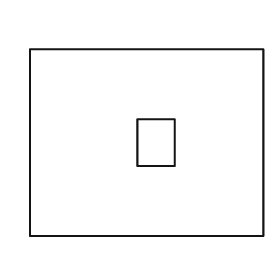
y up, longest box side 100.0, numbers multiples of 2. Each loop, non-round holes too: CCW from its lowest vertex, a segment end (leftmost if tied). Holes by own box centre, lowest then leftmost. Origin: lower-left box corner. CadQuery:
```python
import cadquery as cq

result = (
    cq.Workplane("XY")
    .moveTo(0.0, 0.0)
    .lineTo(100.0, 0.0)
    .lineTo(100.0, 80.0)
    .lineTo(0.0, 80.0)
    .close()
    .moveTo(46.0, 30.0)
    .lineTo(62.0, 30.0)
    .lineTo(62.0, 50.0)
    .lineTo(46.0, 50.0)
    .close()
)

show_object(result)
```